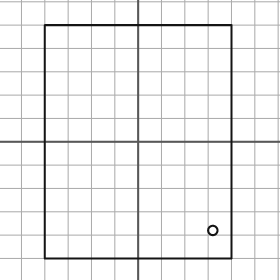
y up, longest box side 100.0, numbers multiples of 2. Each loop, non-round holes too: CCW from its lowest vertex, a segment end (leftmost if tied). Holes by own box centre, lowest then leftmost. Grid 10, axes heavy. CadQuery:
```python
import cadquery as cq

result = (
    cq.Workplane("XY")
    .moveTo(-40.0, -50.0)
    .lineTo(40.0, -50.0)
    .lineTo(40.0, 50.0)
    .lineTo(-40.0, 50.0)
    .close()
    .moveTo(32.0, -38.0)
    .circle(2.0)
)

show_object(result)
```